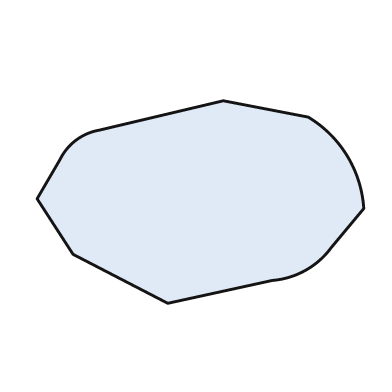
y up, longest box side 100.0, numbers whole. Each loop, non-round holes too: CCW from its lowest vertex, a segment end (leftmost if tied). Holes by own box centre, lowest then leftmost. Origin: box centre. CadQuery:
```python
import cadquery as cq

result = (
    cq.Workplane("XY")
    .moveTo(-10.0, -31.0)
    .lineTo(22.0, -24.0)
    .threePointArc((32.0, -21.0), (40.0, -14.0))
    .lineTo(50.0, -2.0)
    .threePointArc((45.0, 14.0), (33.0, 26.0))
    .lineTo(7.0, 31.0)
    .lineTo(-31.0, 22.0)
    .threePointArc((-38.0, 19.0), (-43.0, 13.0))
    .lineTo(-50.0, 1.0)
    .lineTo(-39.0, -16.0)
    .close()
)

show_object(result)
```